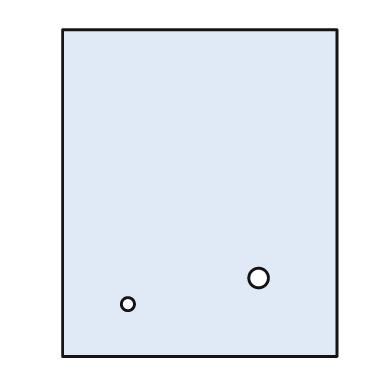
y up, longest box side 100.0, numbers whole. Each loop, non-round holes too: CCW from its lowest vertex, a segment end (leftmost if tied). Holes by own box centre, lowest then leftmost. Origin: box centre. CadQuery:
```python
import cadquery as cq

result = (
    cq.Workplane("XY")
    .moveTo(-42.0, -50.0)
    .lineTo(42.0, -50.0)
    .lineTo(42.0, 50.0)
    .lineTo(-42.0, 50.0)
    .close()
    .moveTo(-22.0, -34.0)
    .circle(2.0)
    .moveTo(18.0, -26.0)
    .circle(3.0)
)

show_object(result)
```